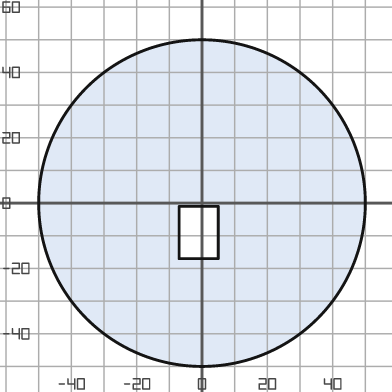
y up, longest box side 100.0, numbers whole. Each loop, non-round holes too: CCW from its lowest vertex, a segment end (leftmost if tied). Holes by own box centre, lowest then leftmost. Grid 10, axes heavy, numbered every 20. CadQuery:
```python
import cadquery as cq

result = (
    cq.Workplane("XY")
    .moveTo(0.0, 0.0)
    .circle(50.0)
    .moveTo(-7.0, -17.0)
    .lineTo(5.0, -17.0)
    .lineTo(5.0, -1.0)
    .lineTo(-7.0, -1.0)
    .close()
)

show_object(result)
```